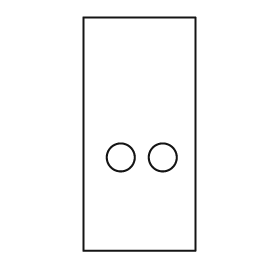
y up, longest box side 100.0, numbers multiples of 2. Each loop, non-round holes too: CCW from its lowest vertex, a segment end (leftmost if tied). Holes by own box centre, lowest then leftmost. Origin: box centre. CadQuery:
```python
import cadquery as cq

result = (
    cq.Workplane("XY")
    .moveTo(-24.0, -50.0)
    .lineTo(24.0, -50.0)
    .lineTo(24.0, 50.0)
    .lineTo(-24.0, 50.0)
    .close()
    .moveTo(-8.0, -10.0)
    .circle(6.0)
    .moveTo(10.0, -10.0)
    .circle(6.0)
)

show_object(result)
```